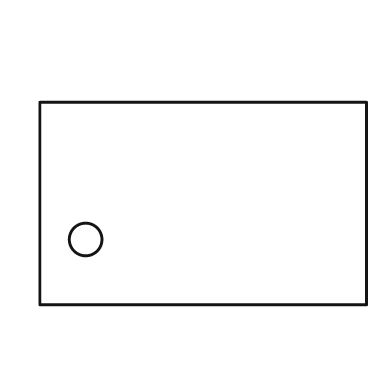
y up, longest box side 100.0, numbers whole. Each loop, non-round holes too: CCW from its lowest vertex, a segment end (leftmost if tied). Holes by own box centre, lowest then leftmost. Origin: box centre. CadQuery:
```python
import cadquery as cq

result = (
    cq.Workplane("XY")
    .moveTo(-50.0, -31.0)
    .lineTo(50.0, -31.0)
    .lineTo(50.0, 31.0)
    .lineTo(-50.0, 31.0)
    .close()
    .moveTo(-36.0, -11.0)
    .circle(5.0)
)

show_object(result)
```